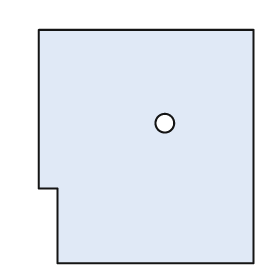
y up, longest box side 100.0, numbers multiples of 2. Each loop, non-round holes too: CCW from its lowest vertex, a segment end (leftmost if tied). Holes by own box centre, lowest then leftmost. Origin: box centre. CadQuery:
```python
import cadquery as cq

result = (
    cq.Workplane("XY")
    .moveTo(-38.0, -50.0)
    .lineTo(46.0, -50.0)
    .lineTo(46.0, 50.0)
    .lineTo(-46.0, 50.0)
    .lineTo(-46.0, -18.0)
    .lineTo(-38.0, -18.0)
    .close()
    .moveTo(8.0, 10.0)
    .circle(4.0)
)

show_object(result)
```